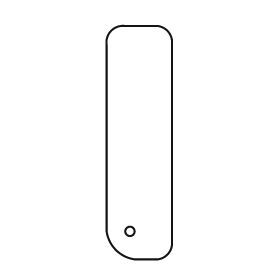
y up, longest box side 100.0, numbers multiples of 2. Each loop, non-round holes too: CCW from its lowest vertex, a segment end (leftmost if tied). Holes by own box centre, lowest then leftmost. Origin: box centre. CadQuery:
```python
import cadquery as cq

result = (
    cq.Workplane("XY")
    .moveTo(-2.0, -50.0)
    .lineTo(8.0, -50.0)
    .threePointArc((12.0, -48.0), (14.0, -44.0))
    .lineTo(14.0, 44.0)
    .threePointArc((12.0, 48.0), (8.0, 50.0))
    .lineTo(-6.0, 50.0)
    .threePointArc((-12.0, 48.0), (-14.0, 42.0))
    .lineTo(-14.0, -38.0)
    .threePointArc((-10.0, -46.0), (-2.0, -50.0))
    .close()
    .moveTo(-4.0, -38.0)
    .circle(2.0)
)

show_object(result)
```